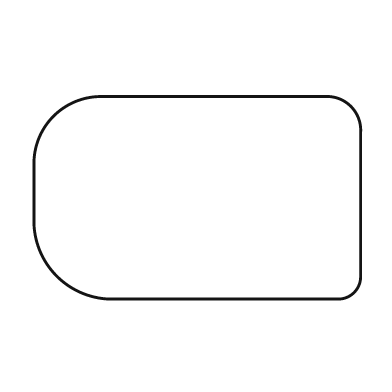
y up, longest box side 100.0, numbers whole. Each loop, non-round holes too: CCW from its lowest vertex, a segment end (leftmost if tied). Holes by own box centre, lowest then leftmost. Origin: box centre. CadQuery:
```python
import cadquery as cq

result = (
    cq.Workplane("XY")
    .moveTo(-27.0, -31.0)
    .lineTo(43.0, -31.0)
    .threePointArc((48.0, -29.0), (50.0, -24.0))
    .lineTo(50.0, 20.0)
    .threePointArc((47.0, 28.0), (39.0, 31.0))
    .lineTo(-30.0, 31.0)
    .threePointArc((-44.0, 25.0), (-50.0, 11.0))
    .lineTo(-50.0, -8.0)
    .threePointArc((-43.0, -24.0), (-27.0, -31.0))
    .close()
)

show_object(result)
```